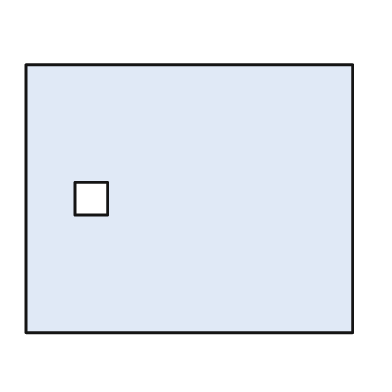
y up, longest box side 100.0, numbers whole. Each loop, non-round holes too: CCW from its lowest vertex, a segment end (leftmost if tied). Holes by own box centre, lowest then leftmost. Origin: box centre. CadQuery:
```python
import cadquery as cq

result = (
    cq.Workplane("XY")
    .moveTo(-50.0, -41.0)
    .lineTo(50.0, -41.0)
    .lineTo(50.0, 41.0)
    .lineTo(-50.0, 41.0)
    .close()
    .moveTo(-35.0, -5.0)
    .lineTo(-25.0, -5.0)
    .lineTo(-25.0, 5.0)
    .lineTo(-35.0, 5.0)
    .close()
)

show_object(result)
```